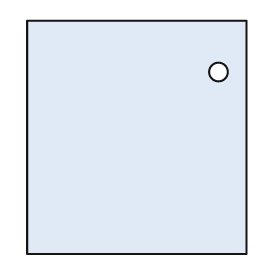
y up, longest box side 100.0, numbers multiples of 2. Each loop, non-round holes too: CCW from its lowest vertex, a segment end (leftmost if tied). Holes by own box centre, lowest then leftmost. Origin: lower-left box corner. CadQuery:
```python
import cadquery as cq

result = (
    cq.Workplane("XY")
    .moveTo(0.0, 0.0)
    .lineTo(94.0, 0.0)
    .lineTo(94.0, 100.0)
    .lineTo(0.0, 100.0)
    .close()
    .moveTo(82.0, 78.0)
    .circle(4.0)
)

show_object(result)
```